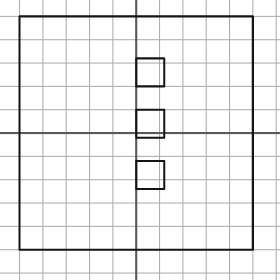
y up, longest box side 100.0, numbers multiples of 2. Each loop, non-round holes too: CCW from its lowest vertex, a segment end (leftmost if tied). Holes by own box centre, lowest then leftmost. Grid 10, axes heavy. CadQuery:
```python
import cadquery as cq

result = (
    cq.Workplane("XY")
    .moveTo(-50.0, -50.0)
    .lineTo(50.0, -50.0)
    .lineTo(50.0, 50.0)
    .lineTo(-50.0, 50.0)
    .close()
    .moveTo(0.0, -24.0)
    .lineTo(12.0, -24.0)
    .lineTo(12.0, -12.0)
    .lineTo(0.0, -12.0)
    .close()
    .moveTo(0.0, -2.0)
    .lineTo(12.0, -2.0)
    .lineTo(12.0, 10.0)
    .lineTo(0.0, 10.0)
    .close()
    .moveTo(0.0, 20.0)
    .lineTo(12.0, 20.0)
    .lineTo(12.0, 32.0)
    .lineTo(0.0, 32.0)
    .close()
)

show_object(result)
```